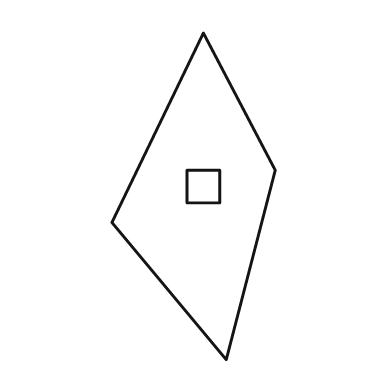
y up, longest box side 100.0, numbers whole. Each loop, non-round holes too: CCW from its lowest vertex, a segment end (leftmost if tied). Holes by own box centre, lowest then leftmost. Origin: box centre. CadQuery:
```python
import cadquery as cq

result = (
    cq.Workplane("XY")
    .moveTo(10.0, -50.0)
    .lineTo(25.0, 8.0)
    .lineTo(3.0, 50.0)
    .lineTo(-25.0, -8.0)
    .close()
    .moveTo(-2.0, -2.0)
    .lineTo(8.0, -2.0)
    .lineTo(8.0, 8.0)
    .lineTo(-2.0, 8.0)
    .close()
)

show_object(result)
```